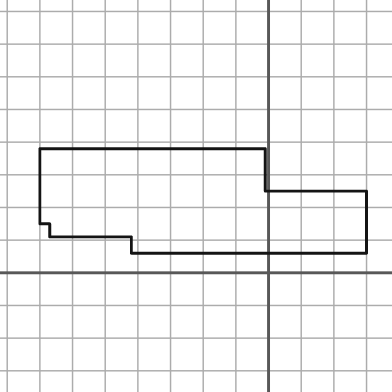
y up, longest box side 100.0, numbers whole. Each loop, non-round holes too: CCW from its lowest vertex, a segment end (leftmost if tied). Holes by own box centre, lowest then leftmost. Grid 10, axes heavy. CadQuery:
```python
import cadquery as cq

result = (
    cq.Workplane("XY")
    .moveTo(-42.0, 6.0)
    .lineTo(30.0, 6.0)
    .lineTo(30.0, 25.0)
    .lineTo(-1.0, 25.0)
    .lineTo(-1.0, 38.0)
    .lineTo(-70.0, 38.0)
    .lineTo(-70.0, 15.0)
    .lineTo(-67.0, 15.0)
    .lineTo(-67.0, 11.0)
    .lineTo(-42.0, 11.0)
    .close()
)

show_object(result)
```